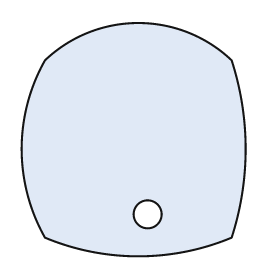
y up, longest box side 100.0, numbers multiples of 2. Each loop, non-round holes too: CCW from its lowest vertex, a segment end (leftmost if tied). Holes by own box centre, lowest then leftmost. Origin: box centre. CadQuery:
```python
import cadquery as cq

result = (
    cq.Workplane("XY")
    .moveTo(-38.0, -42.0)
    .threePointArc((2.0, -50.0), (42.0, -42.0))
    .threePointArc((48.0, -4.0), (42.0, 34.0))
    .threePointArc((2.0, 50.0), (-38.0, 34.0))
    .threePointArc((-48.0, -4.0), (-38.0, -42.0))
    .close()
    .moveTo(6.0, -32.0)
    .circle(6.0)
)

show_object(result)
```